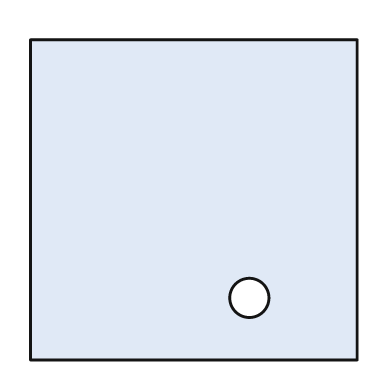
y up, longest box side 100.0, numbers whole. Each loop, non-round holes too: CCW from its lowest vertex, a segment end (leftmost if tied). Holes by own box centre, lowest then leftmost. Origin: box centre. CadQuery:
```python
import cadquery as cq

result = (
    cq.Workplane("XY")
    .moveTo(-50.0, -49.0)
    .lineTo(50.0, -49.0)
    .lineTo(50.0, 49.0)
    .lineTo(-50.0, 49.0)
    .close()
    .moveTo(17.0, -30.0)
    .circle(6.0)
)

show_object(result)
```